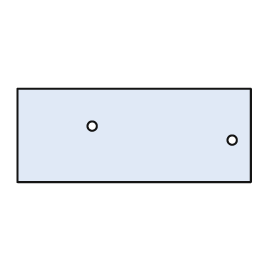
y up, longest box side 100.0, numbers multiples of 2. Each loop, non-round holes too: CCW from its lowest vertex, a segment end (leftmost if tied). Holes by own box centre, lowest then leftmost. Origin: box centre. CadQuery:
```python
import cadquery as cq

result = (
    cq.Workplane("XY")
    .moveTo(-50.0, -20.0)
    .lineTo(50.0, -20.0)
    .lineTo(50.0, 20.0)
    .lineTo(-50.0, 20.0)
    .close()
    .moveTo(42.0, -2.0)
    .circle(2.0)
    .moveTo(-18.0, 4.0)
    .circle(2.0)
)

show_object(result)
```